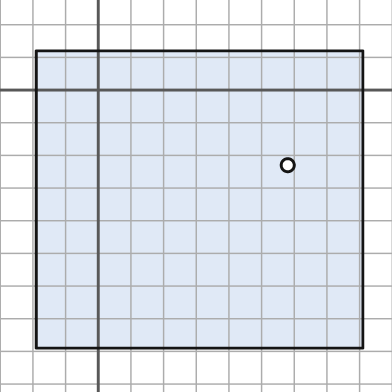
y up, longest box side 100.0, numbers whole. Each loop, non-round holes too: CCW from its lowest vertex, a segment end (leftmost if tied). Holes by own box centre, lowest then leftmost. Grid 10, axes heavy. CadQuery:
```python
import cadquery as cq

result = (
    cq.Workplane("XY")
    .moveTo(-19.0, -79.0)
    .lineTo(81.0, -79.0)
    .lineTo(81.0, 12.0)
    .lineTo(-19.0, 12.0)
    .close()
    .moveTo(58.0, -23.0)
    .circle(2.0)
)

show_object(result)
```